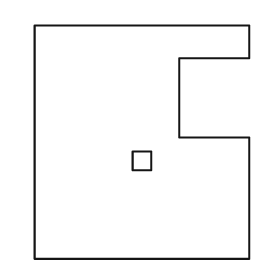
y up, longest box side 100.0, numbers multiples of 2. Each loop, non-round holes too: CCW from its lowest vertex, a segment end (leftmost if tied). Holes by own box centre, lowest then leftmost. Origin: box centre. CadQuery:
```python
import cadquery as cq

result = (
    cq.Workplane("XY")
    .moveTo(-46.0, -50.0)
    .lineTo(46.0, -50.0)
    .lineTo(46.0, 2.0)
    .lineTo(16.0, 2.0)
    .lineTo(16.0, 36.0)
    .lineTo(46.0, 36.0)
    .lineTo(46.0, 50.0)
    .lineTo(-46.0, 50.0)
    .close()
    .moveTo(-4.0, -12.0)
    .lineTo(4.0, -12.0)
    .lineTo(4.0, -4.0)
    .lineTo(-4.0, -4.0)
    .close()
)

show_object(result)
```